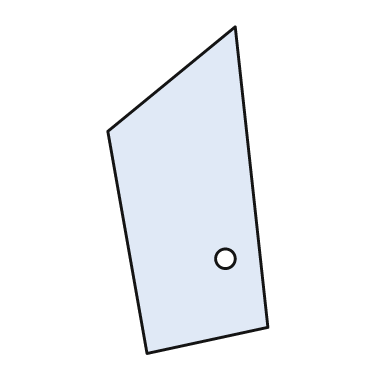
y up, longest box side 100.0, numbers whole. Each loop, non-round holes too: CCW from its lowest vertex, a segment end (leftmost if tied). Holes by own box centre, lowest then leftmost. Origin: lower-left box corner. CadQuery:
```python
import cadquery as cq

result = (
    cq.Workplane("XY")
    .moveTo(12.0, 0.0)
    .lineTo(49.0, 8.0)
    .lineTo(39.0, 100.0)
    .lineTo(0.0, 68.0)
    .close()
    .moveTo(36.0, 29.0)
    .circle(3.0)
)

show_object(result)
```